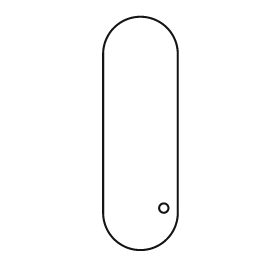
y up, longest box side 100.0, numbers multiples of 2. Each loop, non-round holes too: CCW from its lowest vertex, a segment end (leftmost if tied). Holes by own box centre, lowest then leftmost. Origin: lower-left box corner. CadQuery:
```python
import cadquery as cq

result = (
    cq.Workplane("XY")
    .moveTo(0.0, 16.0)
    .threePointArc((16.0, 0.0), (32.0, 16.0))
    .lineTo(32.0, 84.0)
    .threePointArc((16.0, 100.0), (0.0, 84.0))
    .close()
    .moveTo(26.0, 18.0)
    .circle(2.0)
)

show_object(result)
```